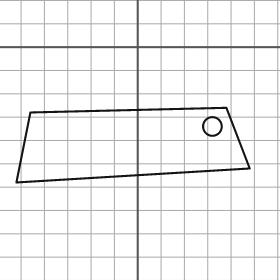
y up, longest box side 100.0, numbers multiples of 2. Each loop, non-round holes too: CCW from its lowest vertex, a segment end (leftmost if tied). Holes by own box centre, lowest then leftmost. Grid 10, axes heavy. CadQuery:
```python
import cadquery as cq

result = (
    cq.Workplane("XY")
    .moveTo(-52.0, -58.0)
    .lineTo(48.0, -52.0)
    .lineTo(38.0, -26.0)
    .lineTo(-46.0, -28.0)
    .close()
    .moveTo(32.0, -34.0)
    .circle(4.0)
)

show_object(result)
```